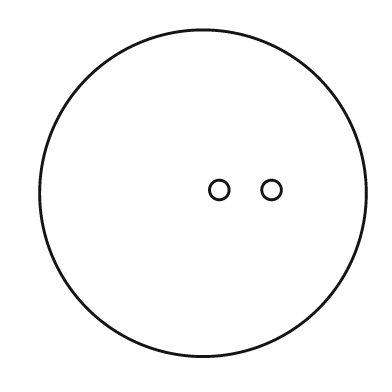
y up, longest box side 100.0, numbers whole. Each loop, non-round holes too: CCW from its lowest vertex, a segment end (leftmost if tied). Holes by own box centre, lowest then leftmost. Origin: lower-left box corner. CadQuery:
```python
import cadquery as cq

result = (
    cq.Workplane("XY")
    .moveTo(50.0, 50.0)
    .circle(50.0)
    .moveTo(55.0, 51.0)
    .circle(3.0)
    .moveTo(71.0, 51.0)
    .circle(3.0)
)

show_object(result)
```